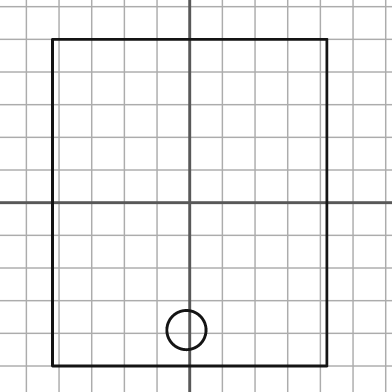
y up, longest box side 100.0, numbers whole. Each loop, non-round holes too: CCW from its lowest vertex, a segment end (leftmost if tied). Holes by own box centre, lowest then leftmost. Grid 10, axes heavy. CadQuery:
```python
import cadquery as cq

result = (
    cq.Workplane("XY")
    .moveTo(-42.0, -50.0)
    .lineTo(42.0, -50.0)
    .lineTo(42.0, 50.0)
    .lineTo(-42.0, 50.0)
    .close()
    .moveTo(-1.0, -39.0)
    .circle(6.0)
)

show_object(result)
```